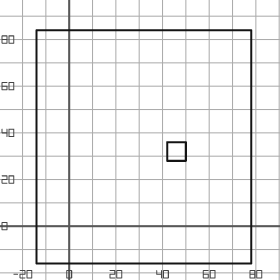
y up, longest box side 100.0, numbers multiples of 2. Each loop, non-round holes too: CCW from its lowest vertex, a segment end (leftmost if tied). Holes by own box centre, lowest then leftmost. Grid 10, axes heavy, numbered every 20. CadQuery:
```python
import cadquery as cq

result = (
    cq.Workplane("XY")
    .moveTo(-14.0, -16.0)
    .lineTo(78.0, -16.0)
    .lineTo(78.0, 84.0)
    .lineTo(-14.0, 84.0)
    .close()
    .moveTo(42.0, 28.0)
    .lineTo(50.0, 28.0)
    .lineTo(50.0, 36.0)
    .lineTo(42.0, 36.0)
    .close()
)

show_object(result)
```